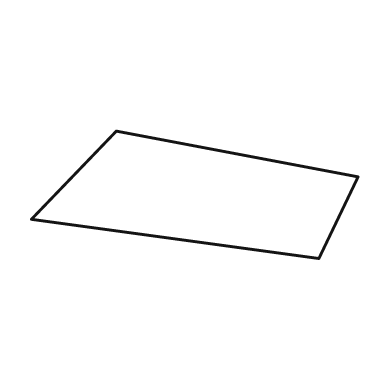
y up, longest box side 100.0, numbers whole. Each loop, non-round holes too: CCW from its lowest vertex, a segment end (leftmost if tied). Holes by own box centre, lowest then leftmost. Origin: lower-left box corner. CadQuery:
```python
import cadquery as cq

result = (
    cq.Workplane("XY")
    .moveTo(88.0, 0.0)
    .lineTo(100.0, 25.0)
    .lineTo(26.0, 39.0)
    .lineTo(0.0, 12.0)
    .close()
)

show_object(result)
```